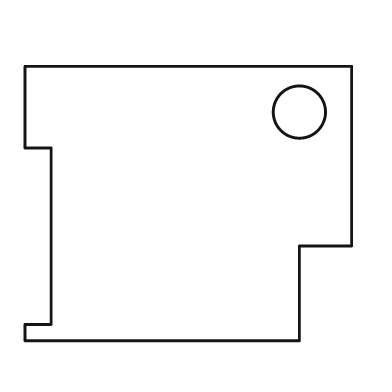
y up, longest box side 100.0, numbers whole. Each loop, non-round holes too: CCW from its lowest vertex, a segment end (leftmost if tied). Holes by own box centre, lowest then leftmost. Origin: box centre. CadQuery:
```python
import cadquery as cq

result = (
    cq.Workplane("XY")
    .moveTo(-50.0, -42.0)
    .lineTo(34.0, -42.0)
    .lineTo(34.0, -13.0)
    .lineTo(50.0, -13.0)
    .lineTo(50.0, 42.0)
    .lineTo(-50.0, 42.0)
    .lineTo(-50.0, 17.0)
    .lineTo(-42.0, 17.0)
    .lineTo(-42.0, -37.0)
    .lineTo(-50.0, -37.0)
    .close()
    .moveTo(34.0, 28.0)
    .circle(8.0)
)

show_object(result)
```